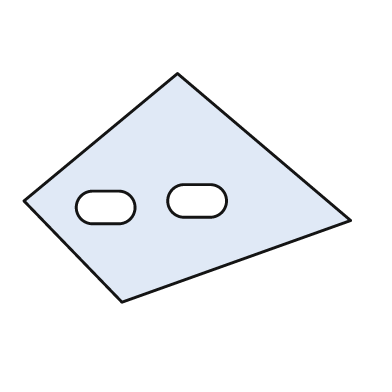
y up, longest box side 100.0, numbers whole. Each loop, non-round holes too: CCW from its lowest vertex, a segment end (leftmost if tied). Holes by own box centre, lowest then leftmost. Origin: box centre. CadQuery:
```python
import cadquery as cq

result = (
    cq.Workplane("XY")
    .moveTo(-20.0, -35.0)
    .lineTo(50.0, -10.0)
    .lineTo(-3.0, 35.0)
    .lineTo(-50.0, -4.0)
    .close()
    .moveTo(-29.0, -11.0)
    .lineTo(-21.0, -11.0)
    .threePointArc((-16.0, -6.0), (-21.0, -1.0))
    .lineTo(-29.0, -1.0)
    .threePointArc((-34.0, -6.0), (-29.0, -11.0))
    .close()
    .moveTo(-1.0, -9.0)
    .lineTo(7.0, -9.0)
    .threePointArc((12.0, -4.0), (7.0, 1.0))
    .lineTo(-1.0, 1.0)
    .threePointArc((-6.0, -4.0), (-1.0, -9.0))
    .close()
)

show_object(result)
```